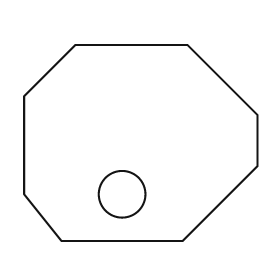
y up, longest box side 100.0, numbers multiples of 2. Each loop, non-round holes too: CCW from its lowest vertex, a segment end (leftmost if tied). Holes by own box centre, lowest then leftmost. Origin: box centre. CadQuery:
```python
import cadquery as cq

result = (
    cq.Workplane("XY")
    .moveTo(-34.0, -42.0)
    .lineTo(18.0, -42.0)
    .lineTo(50.0, -10.0)
    .lineTo(50.0, 12.0)
    .lineTo(20.0, 42.0)
    .lineTo(-28.0, 42.0)
    .lineTo(-50.0, 20.0)
    .lineTo(-50.0, -22.0)
    .close()
    .moveTo(-8.0, -22.0)
    .circle(10.0)
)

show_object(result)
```